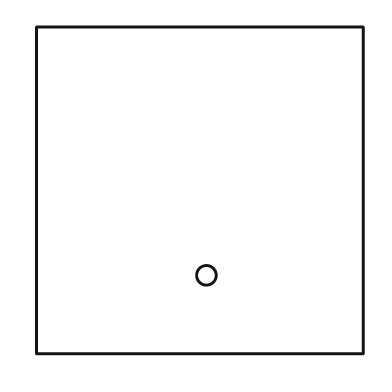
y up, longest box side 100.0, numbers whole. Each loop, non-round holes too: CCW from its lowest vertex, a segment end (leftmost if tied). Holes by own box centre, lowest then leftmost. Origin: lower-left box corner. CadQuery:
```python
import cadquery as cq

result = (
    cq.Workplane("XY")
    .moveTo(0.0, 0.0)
    .lineTo(100.0, 0.0)
    .lineTo(100.0, 100.0)
    .lineTo(0.0, 100.0)
    .close()
    .moveTo(52.0, 24.0)
    .circle(3.0)
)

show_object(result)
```